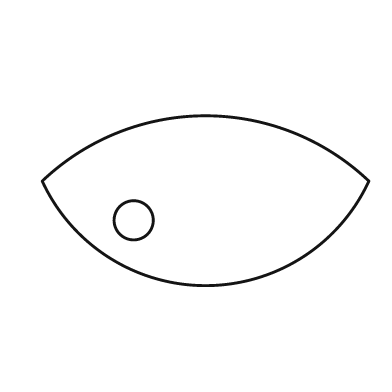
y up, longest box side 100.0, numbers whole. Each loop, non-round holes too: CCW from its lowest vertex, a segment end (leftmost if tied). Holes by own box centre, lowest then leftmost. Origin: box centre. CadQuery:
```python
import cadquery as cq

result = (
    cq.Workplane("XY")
    .moveTo(-50.0, 6.0)
    .threePointArc((0.0, -26.0), (50.0, 6.0))
    .threePointArc((0.0, 26.0), (-50.0, 6.0))
    .close()
    .moveTo(-22.0, -6.0)
    .circle(6.0)
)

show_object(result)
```